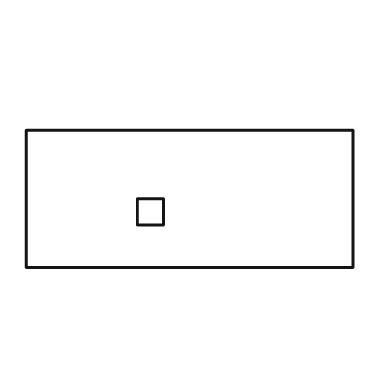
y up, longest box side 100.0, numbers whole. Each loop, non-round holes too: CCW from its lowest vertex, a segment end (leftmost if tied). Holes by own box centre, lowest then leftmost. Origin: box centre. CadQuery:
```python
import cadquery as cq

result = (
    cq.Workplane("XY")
    .moveTo(-50.0, -21.0)
    .lineTo(50.0, -21.0)
    .lineTo(50.0, 21.0)
    .lineTo(-50.0, 21.0)
    .close()
    .moveTo(-16.0, -8.0)
    .lineTo(-8.0, -8.0)
    .lineTo(-8.0, 0.0)
    .lineTo(-16.0, 0.0)
    .close()
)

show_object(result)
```